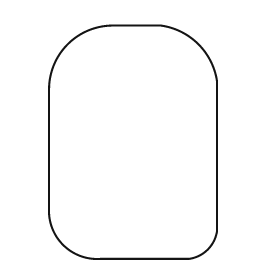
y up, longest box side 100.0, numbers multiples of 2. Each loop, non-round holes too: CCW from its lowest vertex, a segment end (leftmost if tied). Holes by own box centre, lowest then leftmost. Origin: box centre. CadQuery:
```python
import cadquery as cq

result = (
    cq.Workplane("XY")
    .moveTo(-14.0, -50.0)
    .lineTo(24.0, -50.0)
    .threePointArc((32.0, -46.0), (36.0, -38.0))
    .lineTo(36.0, 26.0)
    .threePointArc((28.0, 42.0), (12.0, 50.0))
    .lineTo(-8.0, 50.0)
    .threePointArc((-28.0, 42.0), (-36.0, 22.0))
    .lineTo(-36.0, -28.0)
    .threePointArc((-30.0, -44.0), (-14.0, -50.0))
    .close()
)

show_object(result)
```